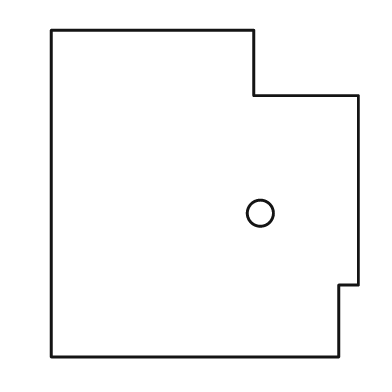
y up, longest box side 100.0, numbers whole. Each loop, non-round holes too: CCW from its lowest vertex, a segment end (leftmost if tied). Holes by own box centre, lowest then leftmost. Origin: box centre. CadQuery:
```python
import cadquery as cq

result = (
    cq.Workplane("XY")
    .moveTo(-47.0, -50.0)
    .lineTo(41.0, -50.0)
    .lineTo(41.0, -28.0)
    .lineTo(47.0, -28.0)
    .lineTo(47.0, 30.0)
    .lineTo(15.0, 30.0)
    .lineTo(15.0, 50.0)
    .lineTo(-47.0, 50.0)
    .close()
    .moveTo(17.0, -6.0)
    .circle(4.0)
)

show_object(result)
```